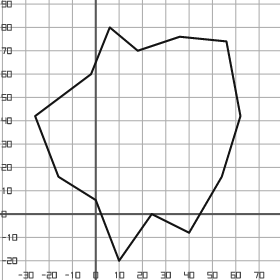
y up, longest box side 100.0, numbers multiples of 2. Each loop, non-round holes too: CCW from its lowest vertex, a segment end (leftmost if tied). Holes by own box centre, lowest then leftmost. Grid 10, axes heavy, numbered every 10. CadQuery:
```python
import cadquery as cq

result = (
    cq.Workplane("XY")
    .moveTo(10.0, -20.0)
    .lineTo(24.0, 0.0)
    .lineTo(40.0, -8.0)
    .lineTo(54.0, 16.0)
    .lineTo(62.0, 42.0)
    .lineTo(56.0, 74.0)
    .lineTo(36.0, 76.0)
    .lineTo(18.0, 70.0)
    .lineTo(6.0, 80.0)
    .lineTo(-2.0, 60.0)
    .lineTo(-26.0, 42.0)
    .lineTo(-16.0, 16.0)
    .lineTo(0.0, 6.0)
    .close()
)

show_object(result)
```